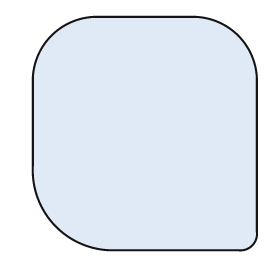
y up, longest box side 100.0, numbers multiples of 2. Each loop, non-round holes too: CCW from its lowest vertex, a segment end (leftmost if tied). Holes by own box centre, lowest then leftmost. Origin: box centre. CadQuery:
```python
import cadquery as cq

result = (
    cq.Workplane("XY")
    .moveTo(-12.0, -50.0)
    .lineTo(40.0, -50.0)
    .threePointArc((46.0, -48.0), (48.0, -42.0))
    .lineTo(48.0, 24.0)
    .threePointArc((40.0, 42.0), (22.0, 50.0))
    .lineTo(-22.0, 50.0)
    .threePointArc((-40.0, 42.0), (-48.0, 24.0))
    .lineTo(-48.0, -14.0)
    .threePointArc((-38.0, -40.0), (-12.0, -50.0))
    .close()
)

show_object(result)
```